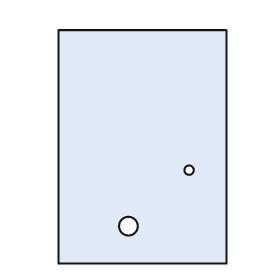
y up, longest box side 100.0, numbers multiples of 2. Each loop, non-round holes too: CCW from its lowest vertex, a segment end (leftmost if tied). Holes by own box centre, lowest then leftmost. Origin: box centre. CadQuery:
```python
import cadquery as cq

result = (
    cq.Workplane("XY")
    .moveTo(-36.0, -50.0)
    .lineTo(36.0, -50.0)
    .lineTo(36.0, 50.0)
    .lineTo(-36.0, 50.0)
    .close()
    .moveTo(-6.0, -34.0)
    .circle(4.0)
    .moveTo(20.0, -10.0)
    .circle(2.0)
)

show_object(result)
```